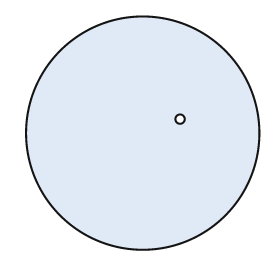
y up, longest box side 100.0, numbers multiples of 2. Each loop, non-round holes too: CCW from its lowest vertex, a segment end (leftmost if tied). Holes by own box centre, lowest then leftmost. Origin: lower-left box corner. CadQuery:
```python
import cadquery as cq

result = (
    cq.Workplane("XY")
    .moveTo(50.0, 50.0)
    .circle(50.0)
    .moveTo(66.0, 56.0)
    .circle(2.0)
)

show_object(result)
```